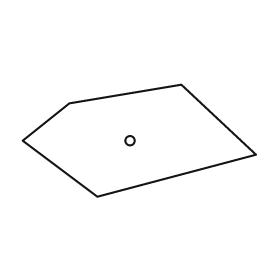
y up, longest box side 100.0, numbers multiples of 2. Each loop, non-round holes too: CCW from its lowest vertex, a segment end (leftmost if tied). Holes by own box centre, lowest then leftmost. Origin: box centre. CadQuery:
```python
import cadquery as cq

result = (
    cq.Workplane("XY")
    .moveTo(-18.0, -24.0)
    .lineTo(50.0, -6.0)
    .lineTo(18.0, 24.0)
    .lineTo(-30.0, 16.0)
    .lineTo(-50.0, 0.0)
    .close()
    .moveTo(-4.0, 0.0)
    .circle(2.0)
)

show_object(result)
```